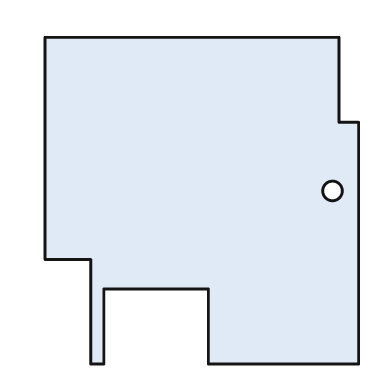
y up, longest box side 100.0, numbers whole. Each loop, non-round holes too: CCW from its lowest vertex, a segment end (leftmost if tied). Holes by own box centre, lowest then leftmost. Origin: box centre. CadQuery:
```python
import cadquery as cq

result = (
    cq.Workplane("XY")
    .moveTo(-34.0, -50.0)
    .lineTo(-30.0, -50.0)
    .lineTo(-30.0, -27.0)
    .lineTo(2.0, -27.0)
    .lineTo(2.0, -50.0)
    .lineTo(48.0, -50.0)
    .lineTo(48.0, 24.0)
    .lineTo(42.0, 24.0)
    .lineTo(42.0, 50.0)
    .lineTo(-48.0, 50.0)
    .lineTo(-48.0, -18.0)
    .lineTo(-34.0, -18.0)
    .close()
    .moveTo(40.0, 3.0)
    .circle(3.0)
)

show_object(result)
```